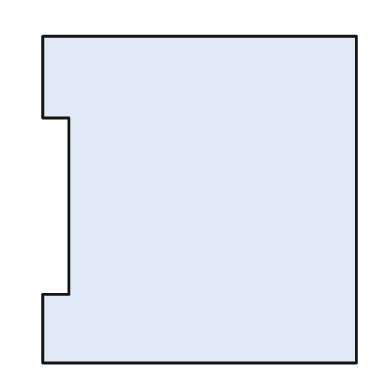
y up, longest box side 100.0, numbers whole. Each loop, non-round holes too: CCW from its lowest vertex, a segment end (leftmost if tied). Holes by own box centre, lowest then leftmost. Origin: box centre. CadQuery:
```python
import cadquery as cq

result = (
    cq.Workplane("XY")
    .moveTo(-48.0, -50.0)
    .lineTo(48.0, -50.0)
    .lineTo(48.0, 50.0)
    .lineTo(-48.0, 50.0)
    .lineTo(-48.0, 25.0)
    .lineTo(-40.0, 25.0)
    .lineTo(-40.0, -29.0)
    .lineTo(-48.0, -29.0)
    .close()
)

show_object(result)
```